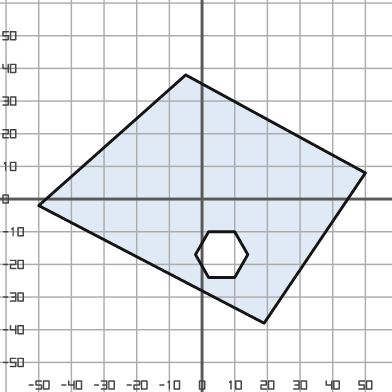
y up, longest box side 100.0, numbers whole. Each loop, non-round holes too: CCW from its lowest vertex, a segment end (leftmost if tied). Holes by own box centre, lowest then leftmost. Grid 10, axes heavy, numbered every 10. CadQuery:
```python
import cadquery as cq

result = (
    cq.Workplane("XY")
    .moveTo(19.0, -38.0)
    .lineTo(50.0, 8.0)
    .lineTo(-5.0, 38.0)
    .lineTo(-50.0, -2.0)
    .close()
    .moveTo(2.0, -24.0)
    .lineTo(10.0, -24.0)
    .lineTo(14.0, -17.0)
    .lineTo(10.0, -10.0)
    .lineTo(2.0, -10.0)
    .lineTo(-2.0, -17.0)
    .close()
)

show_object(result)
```